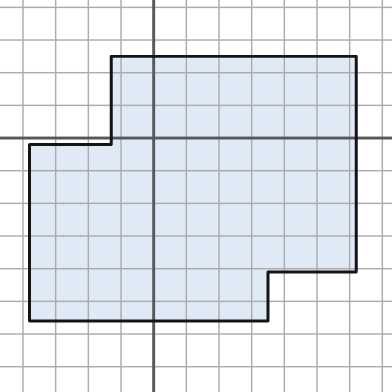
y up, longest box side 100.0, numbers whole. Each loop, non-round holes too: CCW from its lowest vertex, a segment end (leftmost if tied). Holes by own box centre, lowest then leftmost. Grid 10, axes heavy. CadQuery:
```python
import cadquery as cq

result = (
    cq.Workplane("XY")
    .moveTo(-38.0, -56.0)
    .lineTo(35.0, -56.0)
    .lineTo(35.0, -41.0)
    .lineTo(62.0, -41.0)
    .lineTo(62.0, 25.0)
    .lineTo(-13.0, 25.0)
    .lineTo(-13.0, -2.0)
    .lineTo(-38.0, -2.0)
    .close()
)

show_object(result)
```